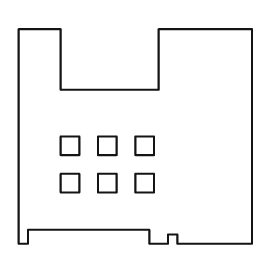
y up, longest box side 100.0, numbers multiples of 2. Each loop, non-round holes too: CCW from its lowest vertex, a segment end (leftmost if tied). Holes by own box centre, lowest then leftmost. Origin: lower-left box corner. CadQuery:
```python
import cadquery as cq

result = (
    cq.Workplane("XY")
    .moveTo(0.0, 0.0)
    .lineTo(4.0, 0.0)
    .lineTo(4.0, 6.0)
    .lineTo(56.0, 6.0)
    .lineTo(56.0, 0.0)
    .lineTo(64.0, 0.0)
    .lineTo(64.0, 4.0)
    .lineTo(68.0, 4.0)
    .lineTo(68.0, 0.0)
    .lineTo(100.0, 0.0)
    .lineTo(100.0, 92.0)
    .lineTo(60.0, 92.0)
    .lineTo(60.0, 66.0)
    .lineTo(18.0, 66.0)
    .lineTo(18.0, 92.0)
    .lineTo(0.0, 92.0)
    .close()
    .moveTo(18.0, 22.0)
    .lineTo(26.0, 22.0)
    .lineTo(26.0, 30.0)
    .lineTo(18.0, 30.0)
    .close()
    .moveTo(34.0, 22.0)
    .lineTo(42.0, 22.0)
    .lineTo(42.0, 30.0)
    .lineTo(34.0, 30.0)
    .close()
    .moveTo(50.0, 22.0)
    .lineTo(58.0, 22.0)
    .lineTo(58.0, 30.0)
    .lineTo(50.0, 30.0)
    .close()
    .moveTo(18.0, 38.0)
    .lineTo(26.0, 38.0)
    .lineTo(26.0, 46.0)
    .lineTo(18.0, 46.0)
    .close()
    .moveTo(34.0, 38.0)
    .lineTo(42.0, 38.0)
    .lineTo(42.0, 46.0)
    .lineTo(34.0, 46.0)
    .close()
    .moveTo(50.0, 38.0)
    .lineTo(58.0, 38.0)
    .lineTo(58.0, 46.0)
    .lineTo(50.0, 46.0)
    .close()
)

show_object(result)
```